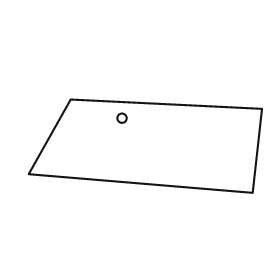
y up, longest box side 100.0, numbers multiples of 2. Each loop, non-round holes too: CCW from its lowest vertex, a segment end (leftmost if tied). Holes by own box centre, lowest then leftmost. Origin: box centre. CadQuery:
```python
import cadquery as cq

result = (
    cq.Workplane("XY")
    .moveTo(46.0, -20.0)
    .lineTo(50.0, 16.0)
    .lineTo(-32.0, 20.0)
    .lineTo(-50.0, -12.0)
    .close()
    .moveTo(-10.0, 12.0)
    .circle(2.0)
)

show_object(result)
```